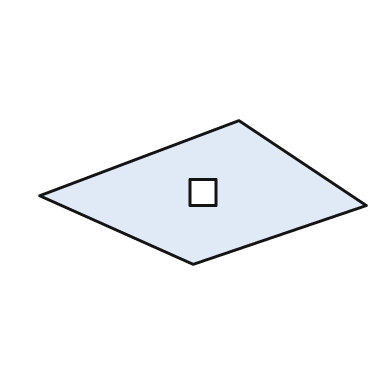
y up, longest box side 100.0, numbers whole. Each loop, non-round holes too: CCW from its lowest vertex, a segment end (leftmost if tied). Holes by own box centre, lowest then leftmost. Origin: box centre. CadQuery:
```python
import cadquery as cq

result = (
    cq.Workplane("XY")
    .moveTo(-3.0, -22.0)
    .lineTo(50.0, -4.0)
    .lineTo(11.0, 22.0)
    .lineTo(-50.0, -1.0)
    .close()
    .moveTo(-4.0, -4.0)
    .lineTo(4.0, -4.0)
    .lineTo(4.0, 4.0)
    .lineTo(-4.0, 4.0)
    .close()
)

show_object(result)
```